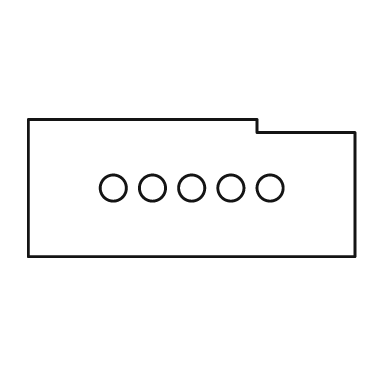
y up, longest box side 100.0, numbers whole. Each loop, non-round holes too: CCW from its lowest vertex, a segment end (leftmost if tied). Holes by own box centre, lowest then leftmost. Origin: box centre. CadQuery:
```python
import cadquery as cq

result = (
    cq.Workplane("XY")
    .moveTo(-50.0, -21.0)
    .lineTo(50.0, -21.0)
    .lineTo(50.0, 17.0)
    .lineTo(20.0, 17.0)
    .lineTo(20.0, 21.0)
    .lineTo(-50.0, 21.0)
    .close()
    .moveTo(-24.0, 0.0)
    .circle(4.0)
    .moveTo(-12.0, 0.0)
    .circle(4.0)
    .moveTo(0.0, 0.0)
    .circle(4.0)
    .moveTo(12.0, 0.0)
    .circle(4.0)
    .moveTo(24.0, 0.0)
    .circle(4.0)
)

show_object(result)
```